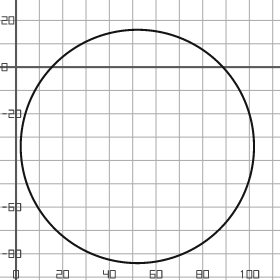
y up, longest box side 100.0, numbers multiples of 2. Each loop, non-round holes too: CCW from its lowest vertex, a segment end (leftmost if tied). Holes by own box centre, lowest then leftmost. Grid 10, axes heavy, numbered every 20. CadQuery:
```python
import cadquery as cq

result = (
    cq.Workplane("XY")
    .moveTo(52.0, -34.0)
    .circle(50.0)
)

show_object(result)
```